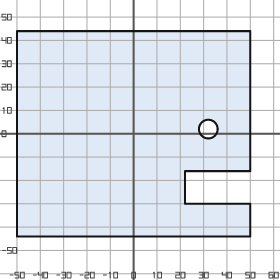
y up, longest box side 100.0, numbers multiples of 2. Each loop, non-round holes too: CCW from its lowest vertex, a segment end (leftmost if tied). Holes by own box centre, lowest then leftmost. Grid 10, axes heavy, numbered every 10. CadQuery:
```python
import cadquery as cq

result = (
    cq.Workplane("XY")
    .moveTo(-50.0, -44.0)
    .lineTo(50.0, -44.0)
    .lineTo(50.0, -30.0)
    .lineTo(22.0, -30.0)
    .lineTo(22.0, -16.0)
    .lineTo(50.0, -16.0)
    .lineTo(50.0, 44.0)
    .lineTo(-50.0, 44.0)
    .close()
    .moveTo(32.0, 2.0)
    .circle(4.0)
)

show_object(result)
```